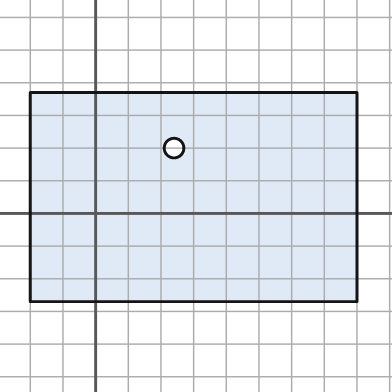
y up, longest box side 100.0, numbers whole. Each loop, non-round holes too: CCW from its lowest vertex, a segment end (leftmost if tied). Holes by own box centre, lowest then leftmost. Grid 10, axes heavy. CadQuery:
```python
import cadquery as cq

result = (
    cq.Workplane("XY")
    .moveTo(-20.0, -27.0)
    .lineTo(80.0, -27.0)
    .lineTo(80.0, 37.0)
    .lineTo(-20.0, 37.0)
    .close()
    .moveTo(24.0, 20.0)
    .circle(3.0)
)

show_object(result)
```